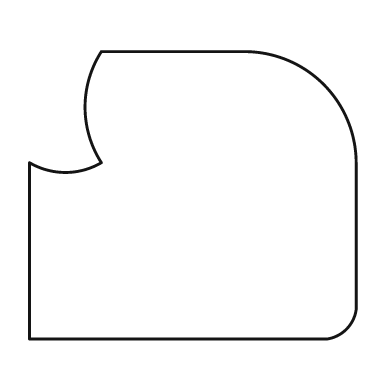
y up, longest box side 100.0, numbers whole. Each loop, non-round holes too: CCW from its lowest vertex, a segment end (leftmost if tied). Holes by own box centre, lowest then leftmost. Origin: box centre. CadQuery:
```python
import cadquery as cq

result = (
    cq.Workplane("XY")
    .moveTo(-50.0, -44.0)
    .lineTo(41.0, -44.0)
    .threePointArc((47.0, -41.0), (50.0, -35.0))
    .lineTo(50.0, 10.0)
    .threePointArc((40.0, 34.0), (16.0, 44.0))
    .lineTo(-28.0, 44.0)
    .threePointArc((-33.0, 27.0), (-28.0, 10.0))
    .threePointArc((-39.0, 7.0), (-50.0, 10.0))
    .close()
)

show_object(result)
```